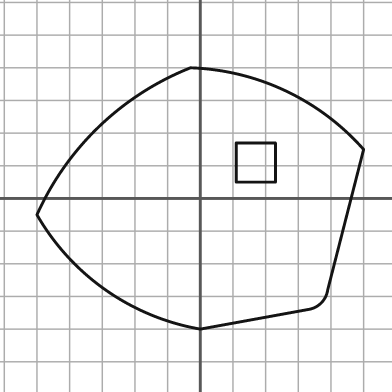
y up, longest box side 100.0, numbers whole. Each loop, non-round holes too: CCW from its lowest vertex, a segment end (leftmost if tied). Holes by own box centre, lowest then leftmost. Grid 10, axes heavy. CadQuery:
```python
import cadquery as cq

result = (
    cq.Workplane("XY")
    .moveTo(0.0, -40.0)
    .lineTo(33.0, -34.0)
    .threePointArc((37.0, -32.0), (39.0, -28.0))
    .lineTo(50.0, 15.0)
    .threePointArc((26.0, 33.0), (-3.0, 40.0))
    .threePointArc((-31.0, 22.0), (-50.0, -5.0))
    .threePointArc((-29.0, -28.0), (0.0, -40.0))
    .close()
    .moveTo(11.0, 5.0)
    .lineTo(23.0, 5.0)
    .lineTo(23.0, 17.0)
    .lineTo(11.0, 17.0)
    .close()
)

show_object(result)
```